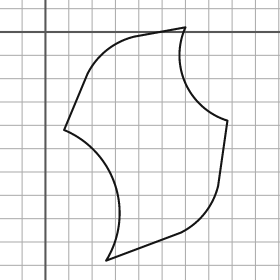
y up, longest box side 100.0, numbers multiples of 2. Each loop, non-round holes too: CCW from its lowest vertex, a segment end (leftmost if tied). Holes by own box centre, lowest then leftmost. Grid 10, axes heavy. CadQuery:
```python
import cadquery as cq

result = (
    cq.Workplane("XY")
    .moveTo(26.0, -98.0)
    .lineTo(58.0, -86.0)
    .threePointArc((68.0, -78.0), (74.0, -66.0))
    .lineTo(78.0, -38.0)
    .threePointArc((60.0, -22.0), (60.0, 2.0))
    .lineTo(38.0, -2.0)
    .threePointArc((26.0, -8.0), (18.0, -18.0))
    .lineTo(8.0, -42.0)
    .threePointArc((30.0, -66.0), (26.0, -98.0))
    .close()
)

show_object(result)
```